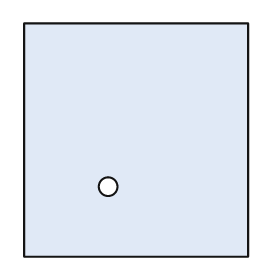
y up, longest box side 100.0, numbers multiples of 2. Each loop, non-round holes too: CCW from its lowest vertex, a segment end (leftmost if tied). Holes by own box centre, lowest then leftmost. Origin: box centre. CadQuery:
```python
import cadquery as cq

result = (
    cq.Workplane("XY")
    .moveTo(-48.0, -50.0)
    .lineTo(48.0, -50.0)
    .lineTo(48.0, 50.0)
    .lineTo(-48.0, 50.0)
    .close()
    .moveTo(-12.0, -20.0)
    .circle(4.0)
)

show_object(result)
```